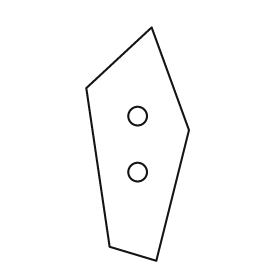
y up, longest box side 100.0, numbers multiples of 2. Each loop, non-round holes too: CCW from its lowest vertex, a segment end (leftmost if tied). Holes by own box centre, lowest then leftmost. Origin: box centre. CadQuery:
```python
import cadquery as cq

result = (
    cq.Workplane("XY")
    .moveTo(8.0, -50.0)
    .lineTo(22.0, 6.0)
    .lineTo(6.0, 50.0)
    .lineTo(-22.0, 24.0)
    .lineTo(-12.0, -44.0)
    .close()
    .moveTo(0.0, -12.0)
    .circle(4.0)
    .moveTo(0.0, 12.0)
    .circle(4.0)
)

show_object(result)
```